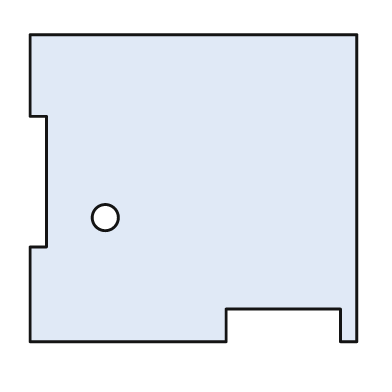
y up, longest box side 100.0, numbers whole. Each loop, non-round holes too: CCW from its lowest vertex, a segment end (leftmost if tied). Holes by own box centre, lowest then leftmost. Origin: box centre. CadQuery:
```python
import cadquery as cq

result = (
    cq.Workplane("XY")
    .moveTo(-50.0, -47.0)
    .lineTo(10.0, -47.0)
    .lineTo(10.0, -37.0)
    .lineTo(45.0, -37.0)
    .lineTo(45.0, -47.0)
    .lineTo(50.0, -47.0)
    .lineTo(50.0, 47.0)
    .lineTo(-50.0, 47.0)
    .lineTo(-50.0, 22.0)
    .lineTo(-45.0, 22.0)
    .lineTo(-45.0, -18.0)
    .lineTo(-50.0, -18.0)
    .close()
    .moveTo(-27.0, -9.0)
    .circle(4.0)
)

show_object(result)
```